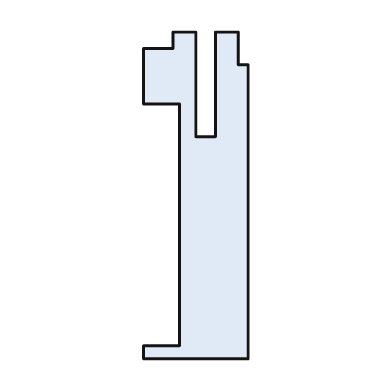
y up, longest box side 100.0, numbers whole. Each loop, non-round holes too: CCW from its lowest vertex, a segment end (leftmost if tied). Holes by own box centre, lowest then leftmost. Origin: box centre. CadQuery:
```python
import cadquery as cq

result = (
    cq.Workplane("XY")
    .moveTo(-16.0, -50.0)
    .lineTo(16.0, -50.0)
    .lineTo(16.0, 40.0)
    .lineTo(13.0, 40.0)
    .lineTo(13.0, 50.0)
    .lineTo(6.0, 50.0)
    .lineTo(6.0, 18.0)
    .lineTo(0.0, 18.0)
    .lineTo(0.0, 50.0)
    .lineTo(-7.0, 50.0)
    .lineTo(-7.0, 45.0)
    .lineTo(-16.0, 45.0)
    .lineTo(-16.0, 28.0)
    .lineTo(-5.0, 28.0)
    .lineTo(-5.0, -46.0)
    .lineTo(-16.0, -46.0)
    .close()
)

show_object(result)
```